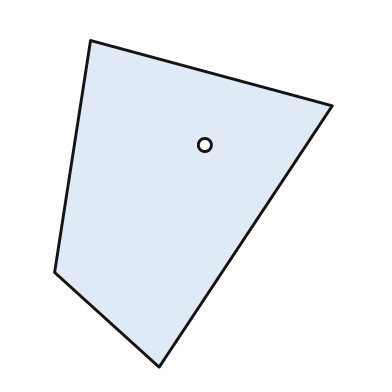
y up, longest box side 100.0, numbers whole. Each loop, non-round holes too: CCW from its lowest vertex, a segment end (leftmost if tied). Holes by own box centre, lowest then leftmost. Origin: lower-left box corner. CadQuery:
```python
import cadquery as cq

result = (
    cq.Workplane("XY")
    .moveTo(32.0, 0.0)
    .lineTo(85.0, 80.0)
    .lineTo(11.0, 100.0)
    .lineTo(0.0, 29.0)
    .close()
    .moveTo(46.0, 68.0)
    .circle(2.0)
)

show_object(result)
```